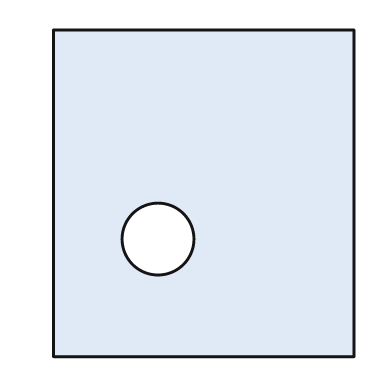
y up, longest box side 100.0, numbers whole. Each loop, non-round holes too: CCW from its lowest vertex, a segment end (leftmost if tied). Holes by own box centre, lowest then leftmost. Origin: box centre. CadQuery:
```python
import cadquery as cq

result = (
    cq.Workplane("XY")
    .moveTo(-46.0, -50.0)
    .lineTo(46.0, -50.0)
    .lineTo(46.0, 50.0)
    .lineTo(-46.0, 50.0)
    .close()
    .moveTo(-14.0, -14.0)
    .circle(11.0)
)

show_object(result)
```